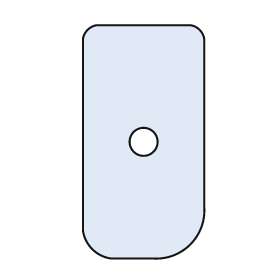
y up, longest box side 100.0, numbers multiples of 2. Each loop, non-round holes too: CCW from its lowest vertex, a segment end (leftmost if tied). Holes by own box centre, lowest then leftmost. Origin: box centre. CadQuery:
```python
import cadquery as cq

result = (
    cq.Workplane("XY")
    .moveTo(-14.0, -50.0)
    .lineTo(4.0, -50.0)
    .threePointArc((20.0, -44.0), (26.0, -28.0))
    .lineTo(26.0, 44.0)
    .threePointArc((24.0, 48.0), (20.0, 50.0))
    .lineTo(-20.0, 50.0)
    .threePointArc((-24.0, 48.0), (-26.0, 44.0))
    .lineTo(-26.0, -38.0)
    .threePointArc((-22.0, -46.0), (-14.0, -50.0))
    .close()
    .moveTo(0.0, 0.0)
    .circle(6.0)
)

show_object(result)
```